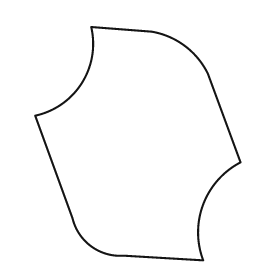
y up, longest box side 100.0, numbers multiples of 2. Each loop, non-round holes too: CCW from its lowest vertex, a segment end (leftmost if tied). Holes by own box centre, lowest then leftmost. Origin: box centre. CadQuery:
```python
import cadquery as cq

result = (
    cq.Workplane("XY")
    .moveTo(28.0, -50.0)
    .threePointArc((28.0, -26.0), (44.0, -8.0))
    .lineTo(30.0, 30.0)
    .threePointArc((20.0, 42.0), (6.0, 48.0))
    .lineTo(-20.0, 50.0)
    .threePointArc((-24.0, 26.0), (-44.0, 12.0))
    .lineTo(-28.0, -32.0)
    .threePointArc((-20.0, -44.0), (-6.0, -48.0))
    .close()
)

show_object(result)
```